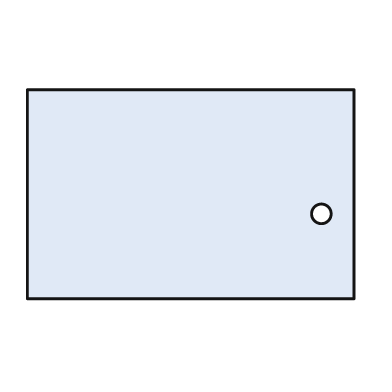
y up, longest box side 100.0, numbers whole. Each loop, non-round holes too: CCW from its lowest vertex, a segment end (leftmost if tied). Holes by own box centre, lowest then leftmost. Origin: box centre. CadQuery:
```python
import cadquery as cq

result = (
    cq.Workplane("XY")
    .moveTo(-50.0, -32.0)
    .lineTo(50.0, -32.0)
    .lineTo(50.0, 32.0)
    .lineTo(-50.0, 32.0)
    .close()
    .moveTo(40.0, -6.0)
    .circle(3.0)
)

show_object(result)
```